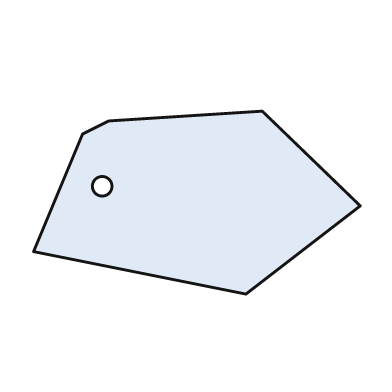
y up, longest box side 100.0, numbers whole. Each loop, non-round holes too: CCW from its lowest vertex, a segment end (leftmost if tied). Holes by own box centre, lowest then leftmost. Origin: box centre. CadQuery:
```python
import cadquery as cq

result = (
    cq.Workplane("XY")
    .moveTo(15.0, -28.0)
    .lineTo(50.0, -1.0)
    .lineTo(20.0, 28.0)
    .lineTo(-27.0, 25.0)
    .lineTo(-35.0, 21.0)
    .lineTo(-50.0, -15.0)
    .close()
    .moveTo(-29.0, 5.0)
    .circle(3.0)
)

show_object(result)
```